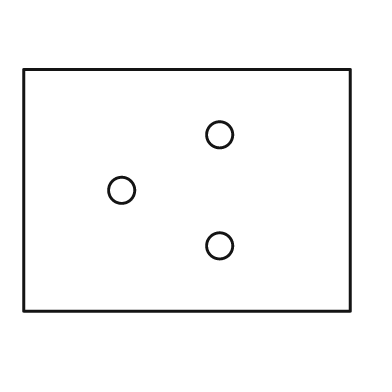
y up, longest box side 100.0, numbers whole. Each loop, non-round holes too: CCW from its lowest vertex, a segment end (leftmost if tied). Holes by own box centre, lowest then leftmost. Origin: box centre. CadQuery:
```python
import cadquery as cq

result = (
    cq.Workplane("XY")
    .moveTo(-50.0, -37.0)
    .lineTo(50.0, -37.0)
    .lineTo(50.0, 37.0)
    .lineTo(-50.0, 37.0)
    .close()
    .moveTo(10.0, -17.0)
    .circle(4.0)
    .moveTo(-20.0, 0.0)
    .circle(4.0)
    .moveTo(10.0, 17.0)
    .circle(4.0)
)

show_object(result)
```